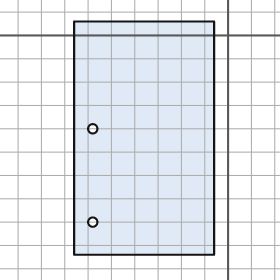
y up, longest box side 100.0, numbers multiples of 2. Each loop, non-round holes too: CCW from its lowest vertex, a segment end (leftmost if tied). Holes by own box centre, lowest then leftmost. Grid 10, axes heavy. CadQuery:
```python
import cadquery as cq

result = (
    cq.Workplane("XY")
    .moveTo(-66.0, -94.0)
    .lineTo(-6.0, -94.0)
    .lineTo(-6.0, 6.0)
    .lineTo(-66.0, 6.0)
    .close()
    .moveTo(-58.0, -80.0)
    .circle(2.0)
    .moveTo(-58.0, -40.0)
    .circle(2.0)
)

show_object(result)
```